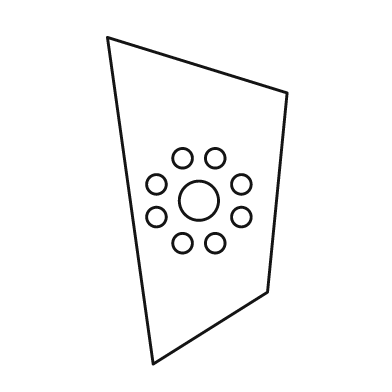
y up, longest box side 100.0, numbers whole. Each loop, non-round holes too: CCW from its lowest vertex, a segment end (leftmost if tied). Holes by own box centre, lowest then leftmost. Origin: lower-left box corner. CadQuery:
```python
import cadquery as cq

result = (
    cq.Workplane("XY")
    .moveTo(14.0, 0.0)
    .lineTo(49.0, 22.0)
    .lineTo(55.0, 83.0)
    .lineTo(0.0, 100.0)
    .close()
    .moveTo(23.0, 37.0)
    .circle(3.0)
    .moveTo(33.0, 37.0)
    .circle(3.0)
    .moveTo(15.0, 45.0)
    .circle(3.0)
    .moveTo(41.0, 45.0)
    .circle(3.0)
    .moveTo(28.0, 50.0)
    .circle(6.0)
    .moveTo(15.0, 55.0)
    .circle(3.0)
    .moveTo(41.0, 55.0)
    .circle(3.0)
    .moveTo(23.0, 63.0)
    .circle(3.0)
    .moveTo(33.0, 63.0)
    .circle(3.0)
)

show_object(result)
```